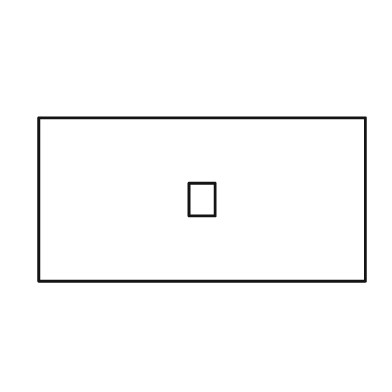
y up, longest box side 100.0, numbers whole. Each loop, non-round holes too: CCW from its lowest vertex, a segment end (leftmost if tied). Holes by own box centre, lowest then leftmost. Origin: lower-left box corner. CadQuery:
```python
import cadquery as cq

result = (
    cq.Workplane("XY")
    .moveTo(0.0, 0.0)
    .lineTo(100.0, 0.0)
    .lineTo(100.0, 50.0)
    .lineTo(0.0, 50.0)
    .close()
    .moveTo(46.0, 20.0)
    .lineTo(54.0, 20.0)
    .lineTo(54.0, 30.0)
    .lineTo(46.0, 30.0)
    .close()
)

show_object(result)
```